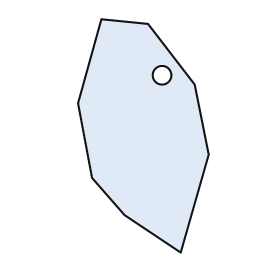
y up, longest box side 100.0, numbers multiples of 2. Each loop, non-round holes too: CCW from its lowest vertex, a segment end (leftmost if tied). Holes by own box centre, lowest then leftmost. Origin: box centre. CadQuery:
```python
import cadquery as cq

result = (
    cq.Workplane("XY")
    .moveTo(16.0, -50.0)
    .lineTo(28.0, -8.0)
    .lineTo(22.0, 22.0)
    .lineTo(2.0, 48.0)
    .lineTo(-18.0, 50.0)
    .lineTo(-28.0, 14.0)
    .lineTo(-22.0, -18.0)
    .lineTo(-8.0, -34.0)
    .close()
    .moveTo(8.0, 26.0)
    .circle(4.0)
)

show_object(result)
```